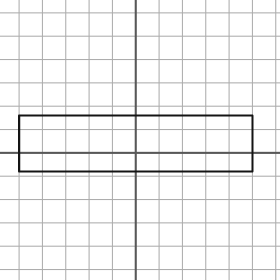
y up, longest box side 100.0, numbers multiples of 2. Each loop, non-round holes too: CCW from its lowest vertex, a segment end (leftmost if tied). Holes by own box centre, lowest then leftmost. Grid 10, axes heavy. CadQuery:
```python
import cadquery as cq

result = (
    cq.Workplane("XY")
    .moveTo(-50.0, -8.0)
    .lineTo(50.0, -8.0)
    .lineTo(50.0, 16.0)
    .lineTo(-50.0, 16.0)
    .close()
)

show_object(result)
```